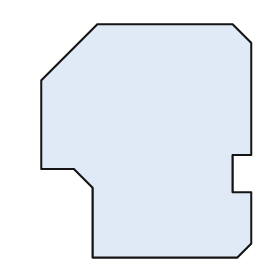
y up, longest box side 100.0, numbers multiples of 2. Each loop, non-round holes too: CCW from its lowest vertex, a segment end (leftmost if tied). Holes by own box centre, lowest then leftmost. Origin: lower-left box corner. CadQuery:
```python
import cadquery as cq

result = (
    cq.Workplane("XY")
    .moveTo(22.0, 0.0)
    .lineTo(84.0, 0.0)
    .lineTo(90.0, 6.0)
    .lineTo(90.0, 28.0)
    .lineTo(82.0, 28.0)
    .lineTo(82.0, 44.0)
    .lineTo(90.0, 44.0)
    .lineTo(90.0, 92.0)
    .lineTo(82.0, 100.0)
    .lineTo(24.0, 100.0)
    .lineTo(0.0, 76.0)
    .lineTo(0.0, 38.0)
    .lineTo(14.0, 38.0)
    .lineTo(22.0, 30.0)
    .close()
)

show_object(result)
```